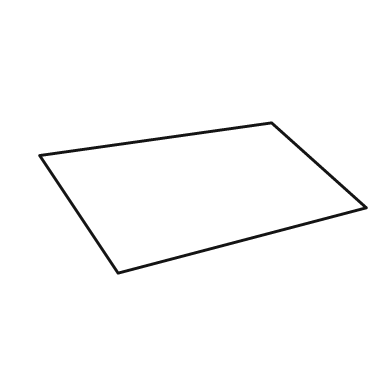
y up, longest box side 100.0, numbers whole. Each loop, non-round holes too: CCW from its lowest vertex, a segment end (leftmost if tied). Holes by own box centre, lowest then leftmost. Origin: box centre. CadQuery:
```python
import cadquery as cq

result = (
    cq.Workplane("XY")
    .moveTo(-26.0, -23.0)
    .lineTo(50.0, -3.0)
    .lineTo(21.0, 23.0)
    .lineTo(-50.0, 13.0)
    .close()
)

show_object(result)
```